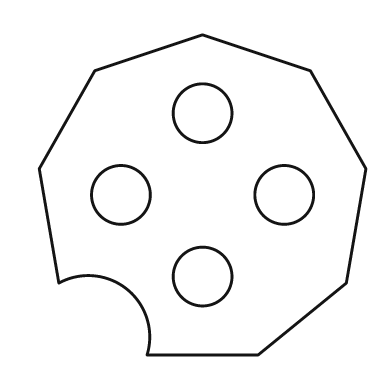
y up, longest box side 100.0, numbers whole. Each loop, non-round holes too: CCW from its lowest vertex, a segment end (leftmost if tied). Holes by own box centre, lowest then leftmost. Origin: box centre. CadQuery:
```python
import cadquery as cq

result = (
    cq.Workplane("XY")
    .moveTo(-17.0, -49.0)
    .lineTo(17.0, -49.0)
    .lineTo(44.0, -27.0)
    .lineTo(50.0, 8.0)
    .lineTo(33.0, 38.0)
    .lineTo(0.0, 49.0)
    .lineTo(-33.0, 38.0)
    .lineTo(-50.0, 8.0)
    .lineTo(-44.0, -27.0)
    .threePointArc((-23.0, -29.0), (-17.0, -49.0))
    .close()
    .moveTo(0.0, -25.0)
    .circle(9.0)
    .moveTo(-25.0, 0.0)
    .circle(9.0)
    .moveTo(25.0, 0.0)
    .circle(9.0)
    .moveTo(0.0, 25.0)
    .circle(9.0)
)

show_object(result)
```